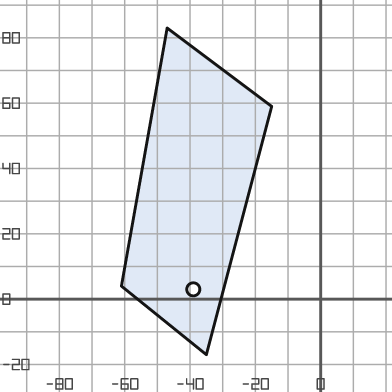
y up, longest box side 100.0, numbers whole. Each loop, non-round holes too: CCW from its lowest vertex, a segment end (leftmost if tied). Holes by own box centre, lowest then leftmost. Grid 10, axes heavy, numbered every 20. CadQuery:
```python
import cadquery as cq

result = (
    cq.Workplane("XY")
    .moveTo(-35.0, -17.0)
    .lineTo(-15.0, 59.0)
    .lineTo(-47.0, 83.0)
    .lineTo(-61.0, 4.0)
    .close()
    .moveTo(-39.0, 3.0)
    .circle(2.0)
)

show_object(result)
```